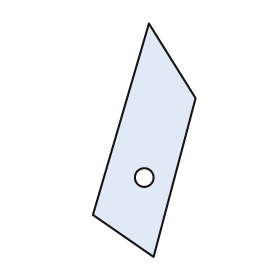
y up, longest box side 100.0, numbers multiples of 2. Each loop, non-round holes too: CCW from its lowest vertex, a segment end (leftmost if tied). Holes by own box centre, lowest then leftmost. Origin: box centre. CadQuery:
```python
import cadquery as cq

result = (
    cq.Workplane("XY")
    .moveTo(4.0, -50.0)
    .lineTo(22.0, 18.0)
    .lineTo(2.0, 50.0)
    .lineTo(-22.0, -32.0)
    .close()
    .moveTo(0.0, -16.0)
    .circle(4.0)
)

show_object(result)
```